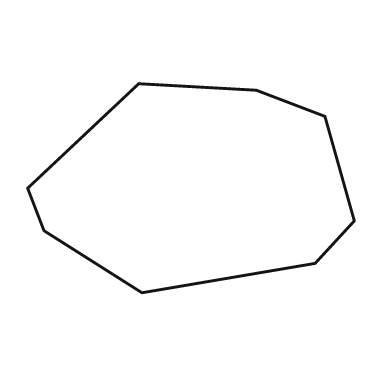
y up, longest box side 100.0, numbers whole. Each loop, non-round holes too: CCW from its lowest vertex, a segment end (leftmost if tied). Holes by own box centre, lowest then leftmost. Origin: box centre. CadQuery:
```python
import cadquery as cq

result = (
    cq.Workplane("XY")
    .moveTo(-15.0, -32.0)
    .lineTo(38.0, -23.0)
    .lineTo(50.0, -10.0)
    .lineTo(41.0, 22.0)
    .lineTo(20.0, 30.0)
    .lineTo(-16.0, 32.0)
    .lineTo(-50.0, 0.0)
    .lineTo(-45.0, -13.0)
    .close()
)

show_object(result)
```